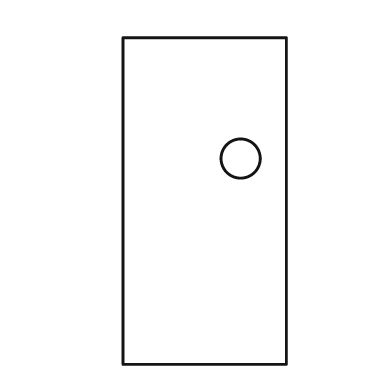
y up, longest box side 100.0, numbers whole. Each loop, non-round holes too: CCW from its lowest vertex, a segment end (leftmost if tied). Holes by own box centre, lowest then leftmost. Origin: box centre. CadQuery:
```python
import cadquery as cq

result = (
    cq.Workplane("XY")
    .moveTo(-25.0, -50.0)
    .lineTo(25.0, -50.0)
    .lineTo(25.0, 50.0)
    .lineTo(-25.0, 50.0)
    .close()
    .moveTo(11.0, 13.0)
    .circle(6.0)
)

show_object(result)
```